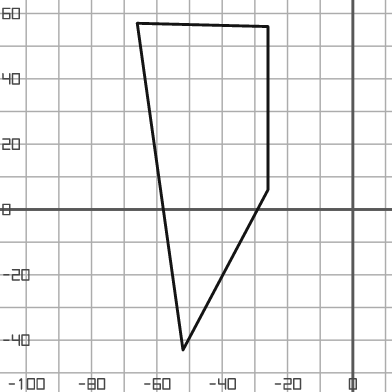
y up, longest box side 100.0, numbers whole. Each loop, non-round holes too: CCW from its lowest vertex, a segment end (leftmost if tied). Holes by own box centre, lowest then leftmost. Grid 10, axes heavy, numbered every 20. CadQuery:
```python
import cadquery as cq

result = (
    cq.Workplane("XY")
    .moveTo(-52.0, -43.0)
    .lineTo(-26.0, 6.0)
    .lineTo(-26.0, 56.0)
    .lineTo(-66.0, 57.0)
    .close()
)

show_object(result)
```